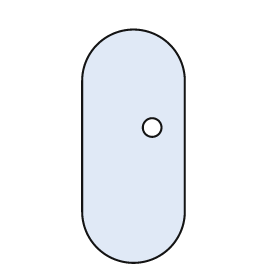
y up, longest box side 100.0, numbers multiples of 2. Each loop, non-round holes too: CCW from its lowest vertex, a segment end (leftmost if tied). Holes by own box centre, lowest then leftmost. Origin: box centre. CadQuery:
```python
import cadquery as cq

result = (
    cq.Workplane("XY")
    .moveTo(-22.0, -28.0)
    .threePointArc((0.0, -50.0), (22.0, -28.0))
    .lineTo(22.0, 28.0)
    .threePointArc((0.0, 50.0), (-22.0, 28.0))
    .close()
    .moveTo(8.0, 8.0)
    .circle(4.0)
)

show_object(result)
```